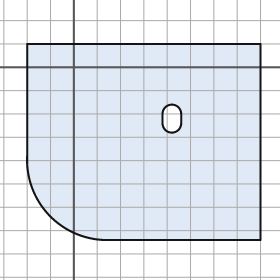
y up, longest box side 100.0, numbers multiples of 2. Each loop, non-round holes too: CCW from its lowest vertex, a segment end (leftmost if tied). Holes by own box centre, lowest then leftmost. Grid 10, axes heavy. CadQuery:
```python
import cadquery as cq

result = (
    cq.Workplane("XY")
    .moveTo(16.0, -74.0)
    .lineTo(80.0, -74.0)
    .lineTo(80.0, 10.0)
    .lineTo(-20.0, 10.0)
    .lineTo(-20.0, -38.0)
    .threePointArc((-10.0, -64.0), (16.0, -74.0))
    .close()
    .moveTo(38.0, -24.0)
    .threePointArc((42.0, -28.0), (46.0, -24.0))
    .lineTo(46.0, -20.0)
    .threePointArc((42.0, -16.0), (38.0, -20.0))
    .close()
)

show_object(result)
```